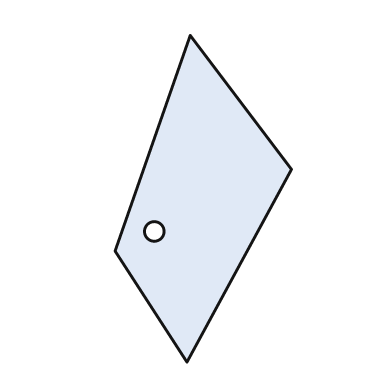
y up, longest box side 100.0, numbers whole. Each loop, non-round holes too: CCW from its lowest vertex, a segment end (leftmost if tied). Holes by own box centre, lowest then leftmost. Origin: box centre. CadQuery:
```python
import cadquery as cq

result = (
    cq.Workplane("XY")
    .moveTo(-5.0, -50.0)
    .lineTo(27.0, 9.0)
    .lineTo(-4.0, 50.0)
    .lineTo(-27.0, -16.0)
    .close()
    .moveTo(-15.0, -10.0)
    .circle(3.0)
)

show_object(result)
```